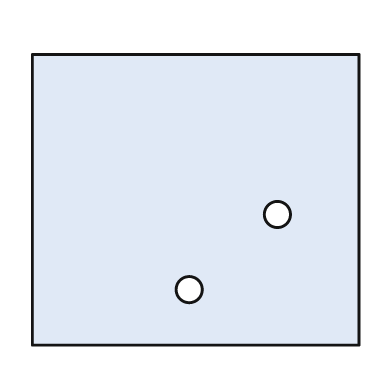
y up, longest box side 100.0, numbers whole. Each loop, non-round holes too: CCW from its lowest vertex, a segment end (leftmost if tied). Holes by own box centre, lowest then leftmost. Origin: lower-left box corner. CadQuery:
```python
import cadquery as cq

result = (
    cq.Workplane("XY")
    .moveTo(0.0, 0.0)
    .lineTo(100.0, 0.0)
    .lineTo(100.0, 89.0)
    .lineTo(0.0, 89.0)
    .close()
    .moveTo(48.0, 17.0)
    .circle(4.0)
    .moveTo(75.0, 40.0)
    .circle(4.0)
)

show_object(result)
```